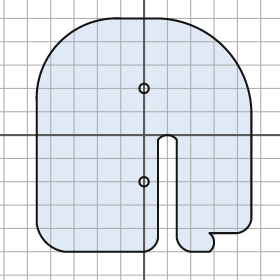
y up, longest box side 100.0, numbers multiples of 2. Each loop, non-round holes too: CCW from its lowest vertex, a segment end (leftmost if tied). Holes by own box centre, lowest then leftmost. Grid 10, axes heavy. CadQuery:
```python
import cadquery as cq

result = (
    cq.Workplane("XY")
    .moveTo(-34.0, -50.0)
    .lineTo(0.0, -50.0)
    .threePointArc((4.0, -48.0), (6.0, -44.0))
    .lineTo(6.0, -2.0)
    .threePointArc((10.0, 0.0), (14.0, -2.0))
    .lineTo(14.0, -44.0)
    .threePointArc((16.0, -48.0), (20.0, -50.0))
    .lineTo(28.0, -50.0)
    .threePointArc((30.0, -46.0), (28.0, -42.0))
    .lineTo(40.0, -42.0)
    .threePointArc((44.0, -40.0), (46.0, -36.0))
    .lineTo(46.0, 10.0)
    .threePointArc((34.0, 38.0), (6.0, 50.0))
    .lineTo(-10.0, 50.0)
    .threePointArc((-36.0, 40.0), (-46.0, 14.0))
    .lineTo(-46.0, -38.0)
    .threePointArc((-42.0, -46.0), (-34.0, -50.0))
    .close()
    .moveTo(0.0, -20.0)
    .circle(2.0)
    .moveTo(0.0, 20.0)
    .circle(2.0)
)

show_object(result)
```